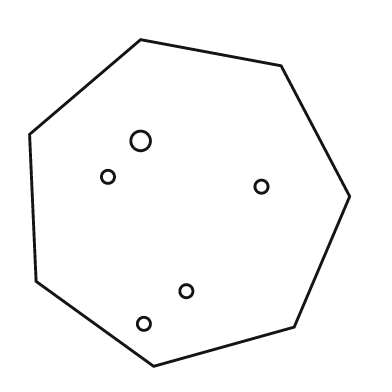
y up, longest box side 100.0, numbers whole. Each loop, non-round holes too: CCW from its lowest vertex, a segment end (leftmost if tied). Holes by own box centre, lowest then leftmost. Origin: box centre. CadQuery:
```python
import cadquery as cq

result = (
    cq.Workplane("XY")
    .moveTo(-11.0, -50.0)
    .lineTo(32.0, -38.0)
    .lineTo(49.0, 2.0)
    .lineTo(28.0, 42.0)
    .lineTo(-15.0, 50.0)
    .lineTo(-49.0, 21.0)
    .lineTo(-47.0, -24.0)
    .close()
    .moveTo(-14.0, -37.0)
    .circle(2.0)
    .moveTo(-1.0, -27.0)
    .circle(2.0)
    .moveTo(22.0, 5.0)
    .circle(2.0)
    .moveTo(-25.0, 8.0)
    .circle(2.0)
    .moveTo(-15.0, 19.0)
    .circle(3.0)
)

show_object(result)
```